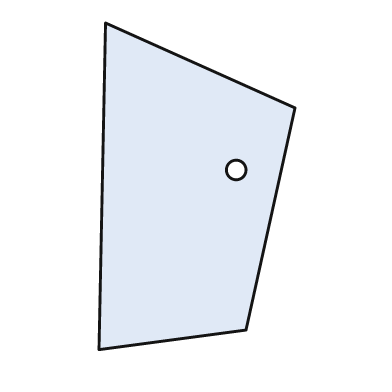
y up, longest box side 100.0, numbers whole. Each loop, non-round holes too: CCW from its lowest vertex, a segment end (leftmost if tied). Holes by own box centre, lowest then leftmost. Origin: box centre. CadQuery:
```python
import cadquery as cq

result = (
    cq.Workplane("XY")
    .moveTo(-30.0, -50.0)
    .lineTo(15.0, -44.0)
    .lineTo(30.0, 24.0)
    .lineTo(-28.0, 50.0)
    .close()
    .moveTo(12.0, 5.0)
    .circle(3.0)
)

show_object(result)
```